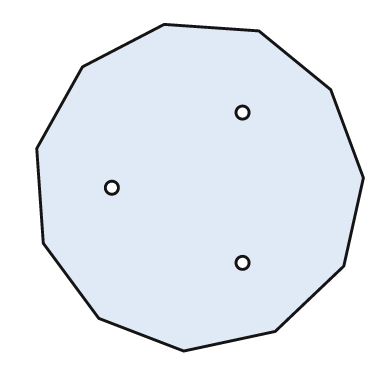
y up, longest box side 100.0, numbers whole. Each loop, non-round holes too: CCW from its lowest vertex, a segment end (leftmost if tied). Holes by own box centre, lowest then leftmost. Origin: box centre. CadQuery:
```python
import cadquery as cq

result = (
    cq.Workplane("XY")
    .moveTo(-5.0, -50.0)
    .lineTo(23.0, -44.0)
    .lineTo(44.0, -24.0)
    .lineTo(50.0, 3.0)
    .lineTo(40.0, 30.0)
    .lineTo(18.0, 48.0)
    .lineTo(-11.0, 50.0)
    .lineTo(-36.0, 37.0)
    .lineTo(-50.0, 12.0)
    .lineTo(-48.0, -17.0)
    .lineTo(-31.0, -40.0)
    .close()
    .moveTo(13.0, -23.0)
    .circle(2.0)
    .moveTo(-27.0, 0.0)
    .circle(2.0)
    .moveTo(13.0, 23.0)
    .circle(2.0)
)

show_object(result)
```